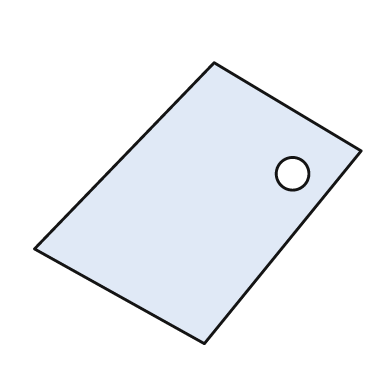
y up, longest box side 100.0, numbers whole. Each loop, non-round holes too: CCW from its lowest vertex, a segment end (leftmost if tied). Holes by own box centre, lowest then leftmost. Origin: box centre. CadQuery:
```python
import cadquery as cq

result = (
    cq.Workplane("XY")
    .moveTo(2.0, -43.0)
    .lineTo(50.0, 16.0)
    .lineTo(5.0, 43.0)
    .lineTo(-50.0, -14.0)
    .close()
    .moveTo(29.0, 9.0)
    .circle(5.0)
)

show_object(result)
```